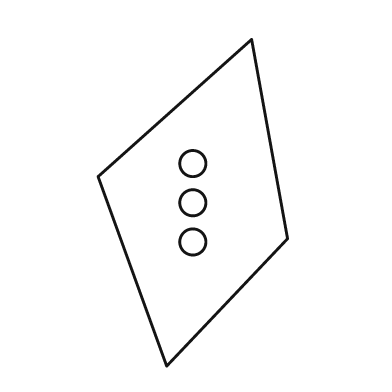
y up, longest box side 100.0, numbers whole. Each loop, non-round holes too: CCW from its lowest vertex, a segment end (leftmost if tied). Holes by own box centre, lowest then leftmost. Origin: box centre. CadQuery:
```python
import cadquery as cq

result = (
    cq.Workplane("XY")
    .moveTo(-8.0, -50.0)
    .lineTo(29.0, -11.0)
    .lineTo(18.0, 50.0)
    .lineTo(-29.0, 8.0)
    .close()
    .moveTo(0.0, -12.0)
    .circle(4.0)
    .moveTo(0.0, 0.0)
    .circle(4.0)
    .moveTo(0.0, 12.0)
    .circle(4.0)
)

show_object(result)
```